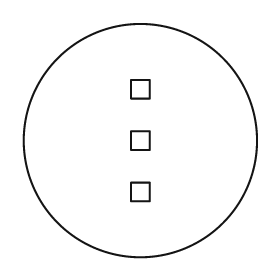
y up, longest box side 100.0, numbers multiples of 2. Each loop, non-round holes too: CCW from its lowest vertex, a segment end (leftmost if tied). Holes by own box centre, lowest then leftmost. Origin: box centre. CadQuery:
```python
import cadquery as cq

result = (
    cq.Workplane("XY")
    .moveTo(0.0, 0.0)
    .circle(50.0)
    .moveTo(-4.0, -26.0)
    .lineTo(4.0, -26.0)
    .lineTo(4.0, -18.0)
    .lineTo(-4.0, -18.0)
    .close()
    .moveTo(-4.0, -4.0)
    .lineTo(4.0, -4.0)
    .lineTo(4.0, 4.0)
    .lineTo(-4.0, 4.0)
    .close()
    .moveTo(-4.0, 18.0)
    .lineTo(4.0, 18.0)
    .lineTo(4.0, 26.0)
    .lineTo(-4.0, 26.0)
    .close()
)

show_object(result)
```